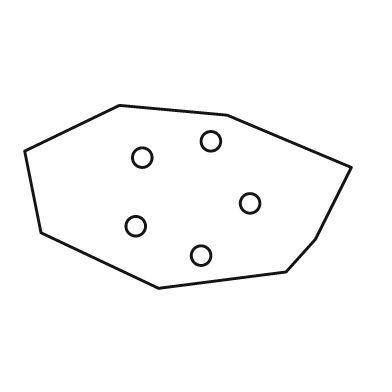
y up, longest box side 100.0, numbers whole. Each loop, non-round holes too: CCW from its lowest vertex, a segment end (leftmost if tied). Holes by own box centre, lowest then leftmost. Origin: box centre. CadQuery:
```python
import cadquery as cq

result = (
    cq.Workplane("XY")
    .moveTo(-9.0, -28.0)
    .lineTo(30.0, -23.0)
    .lineTo(39.0, -13.0)
    .lineTo(50.0, 9.0)
    .lineTo(12.0, 25.0)
    .lineTo(-21.0, 28.0)
    .lineTo(-50.0, 14.0)
    .lineTo(-45.0, -11.0)
    .close()
    .moveTo(4.0, -18.0)
    .circle(3.0)
    .moveTo(-16.0, -9.0)
    .circle(3.0)
    .moveTo(19.0, -2.0)
    .circle(3.0)
    .moveTo(-14.0, 12.0)
    .circle(3.0)
    .moveTo(7.0, 17.0)
    .circle(3.0)
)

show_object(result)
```